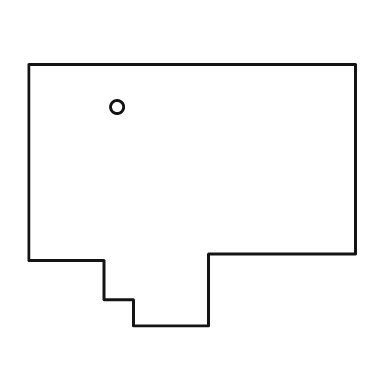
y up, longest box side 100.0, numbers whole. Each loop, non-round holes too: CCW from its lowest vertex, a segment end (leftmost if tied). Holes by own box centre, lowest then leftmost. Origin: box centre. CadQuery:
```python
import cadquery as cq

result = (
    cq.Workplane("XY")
    .moveTo(-18.0, -40.0)
    .lineTo(5.0, -40.0)
    .lineTo(5.0, -18.0)
    .lineTo(50.0, -18.0)
    .lineTo(50.0, 40.0)
    .lineTo(-50.0, 40.0)
    .lineTo(-50.0, -20.0)
    .lineTo(-27.0, -20.0)
    .lineTo(-27.0, -32.0)
    .lineTo(-18.0, -32.0)
    .close()
    .moveTo(-23.0, 27.0)
    .circle(2.0)
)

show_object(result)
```